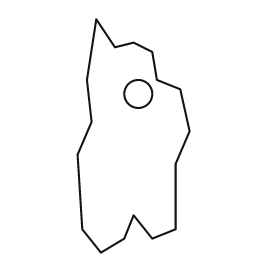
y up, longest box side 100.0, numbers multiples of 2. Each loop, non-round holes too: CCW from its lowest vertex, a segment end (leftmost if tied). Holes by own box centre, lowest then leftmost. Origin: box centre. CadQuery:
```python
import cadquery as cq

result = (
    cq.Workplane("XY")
    .moveTo(-14.0, -50.0)
    .lineTo(-4.0, -44.0)
    .lineTo(0.0, -34.0)
    .lineTo(8.0, -44.0)
    .lineTo(18.0, -40.0)
    .lineTo(18.0, -12.0)
    .lineTo(24.0, 2.0)
    .lineTo(20.0, 20.0)
    .lineTo(10.0, 24.0)
    .lineTo(8.0, 36.0)
    .lineTo(0.0, 40.0)
    .lineTo(-8.0, 38.0)
    .lineTo(-16.0, 50.0)
    .lineTo(-20.0, 24.0)
    .lineTo(-18.0, 6.0)
    .lineTo(-24.0, -8.0)
    .lineTo(-22.0, -40.0)
    .close()
    .moveTo(2.0, 18.0)
    .circle(6.0)
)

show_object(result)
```